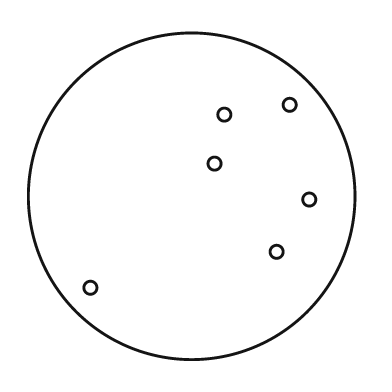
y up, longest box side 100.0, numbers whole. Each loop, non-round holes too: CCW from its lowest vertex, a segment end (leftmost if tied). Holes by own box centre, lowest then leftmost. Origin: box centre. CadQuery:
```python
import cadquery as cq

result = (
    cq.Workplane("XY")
    .moveTo(0.0, 0.0)
    .circle(50.0)
    .moveTo(-31.0, -28.0)
    .circle(2.0)
    .moveTo(26.0, -17.0)
    .circle(2.0)
    .moveTo(36.0, -1.0)
    .circle(2.0)
    .moveTo(7.0, 10.0)
    .circle(2.0)
    .moveTo(10.0, 25.0)
    .circle(2.0)
    .moveTo(30.0, 28.0)
    .circle(2.0)
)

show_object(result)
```